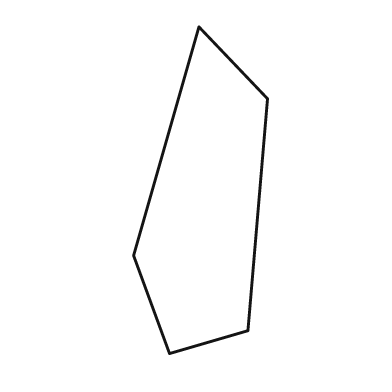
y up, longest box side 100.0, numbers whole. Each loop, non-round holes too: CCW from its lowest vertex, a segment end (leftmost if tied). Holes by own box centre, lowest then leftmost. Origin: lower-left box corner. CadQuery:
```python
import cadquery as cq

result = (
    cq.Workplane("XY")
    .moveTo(11.0, 0.0)
    .lineTo(35.0, 7.0)
    .lineTo(41.0, 78.0)
    .lineTo(20.0, 100.0)
    .lineTo(0.0, 30.0)
    .close()
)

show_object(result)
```